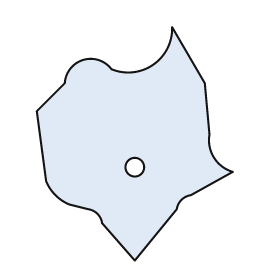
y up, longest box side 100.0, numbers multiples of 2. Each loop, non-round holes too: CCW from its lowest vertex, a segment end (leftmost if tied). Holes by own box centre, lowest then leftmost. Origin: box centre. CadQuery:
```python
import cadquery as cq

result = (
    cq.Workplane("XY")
    .moveTo(0.0, -50.0)
    .lineTo(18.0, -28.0)
    .threePointArc((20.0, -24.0), (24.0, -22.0))
    .lineTo(42.0, -12.0)
    .threePointArc((34.0, -6.0), (32.0, 4.0))
    .lineTo(30.0, 26.0)
    .lineTo(16.0, 50.0)
    .threePointArc((8.0, 34.0), (-10.0, 32.0))
    .threePointArc((-22.0, 36.0), (-30.0, 26.0))
    .lineTo(-42.0, 14.0)
    .lineTo(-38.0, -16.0)
    .threePointArc((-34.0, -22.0), (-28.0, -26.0))
    .lineTo(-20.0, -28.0)
    .threePointArc((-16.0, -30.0), (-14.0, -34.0))
    .close()
    .moveTo(0.0, -10.0)
    .circle(4.0)
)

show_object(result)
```